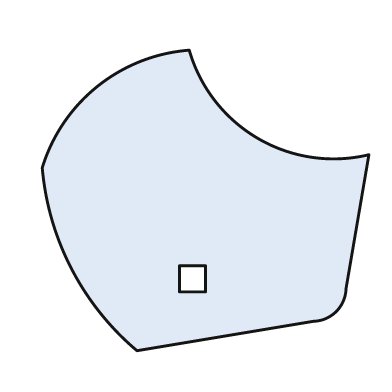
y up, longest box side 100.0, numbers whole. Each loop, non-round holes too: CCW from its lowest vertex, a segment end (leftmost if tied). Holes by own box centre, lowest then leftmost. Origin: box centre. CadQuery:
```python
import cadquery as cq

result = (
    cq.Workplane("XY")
    .moveTo(-21.0, -46.0)
    .lineTo(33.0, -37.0)
    .threePointArc((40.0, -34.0), (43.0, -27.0))
    .lineTo(50.0, 14.0)
    .threePointArc((16.0, 19.0), (-5.0, 46.0))
    .threePointArc((-33.0, 35.0), (-50.0, 10.0))
    .threePointArc((-41.0, -21.0), (-21.0, -46.0))
    .close()
    .moveTo(-8.0, -28.0)
    .lineTo(0.0, -28.0)
    .lineTo(0.0, -20.0)
    .lineTo(-8.0, -20.0)
    .close()
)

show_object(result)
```